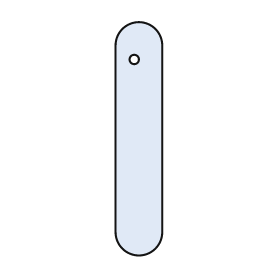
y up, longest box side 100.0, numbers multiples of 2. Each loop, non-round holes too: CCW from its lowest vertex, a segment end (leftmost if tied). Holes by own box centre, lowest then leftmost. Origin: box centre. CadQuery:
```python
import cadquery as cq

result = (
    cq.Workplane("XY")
    .moveTo(-10.0, -40.0)
    .threePointArc((0.0, -50.0), (10.0, -40.0))
    .lineTo(10.0, 40.0)
    .threePointArc((0.0, 50.0), (-10.0, 40.0))
    .close()
    .moveTo(-2.0, 34.0)
    .circle(2.0)
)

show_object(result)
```